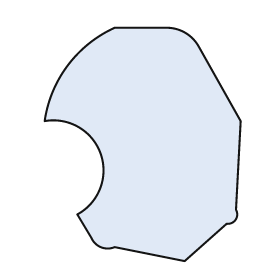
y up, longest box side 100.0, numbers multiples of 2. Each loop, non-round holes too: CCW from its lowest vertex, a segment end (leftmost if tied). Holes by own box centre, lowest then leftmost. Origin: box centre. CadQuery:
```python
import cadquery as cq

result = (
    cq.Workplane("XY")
    .moveTo(18.0, -50.0)
    .lineTo(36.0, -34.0)
    .threePointArc((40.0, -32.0), (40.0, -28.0))
    .lineTo(42.0, 10.0)
    .lineTo(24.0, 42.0)
    .threePointArc((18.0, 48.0), (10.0, 50.0))
    .lineTo(-12.0, 50.0)
    .threePointArc((-32.0, 34.0), (-42.0, 10.0))
    .threePointArc((-18.0, -4.0), (-28.0, -30.0))
    .lineTo(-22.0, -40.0)
    .threePointArc((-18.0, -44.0), (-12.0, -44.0))
    .close()
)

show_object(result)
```